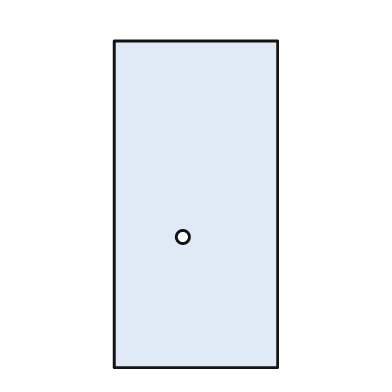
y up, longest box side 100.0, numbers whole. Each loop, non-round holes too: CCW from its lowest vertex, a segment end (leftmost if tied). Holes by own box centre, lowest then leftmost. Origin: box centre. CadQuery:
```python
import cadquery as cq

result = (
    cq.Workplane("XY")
    .moveTo(-25.0, -50.0)
    .lineTo(25.0, -50.0)
    .lineTo(25.0, 50.0)
    .lineTo(-25.0, 50.0)
    .close()
    .moveTo(-4.0, -10.0)
    .circle(2.0)
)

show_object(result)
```